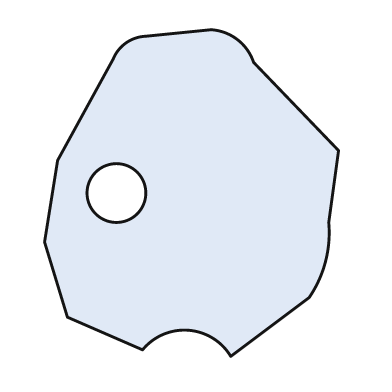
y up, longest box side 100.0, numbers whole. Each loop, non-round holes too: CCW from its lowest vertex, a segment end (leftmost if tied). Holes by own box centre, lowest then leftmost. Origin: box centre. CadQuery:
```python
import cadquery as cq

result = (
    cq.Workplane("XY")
    .moveTo(12.0, -50.0)
    .lineTo(36.0, -32.0)
    .threePointArc((41.0, -21.0), (42.0, -9.0))
    .lineTo(45.0, 13.0)
    .lineTo(19.0, 40.0)
    .threePointArc((14.0, 47.0), (6.0, 50.0))
    .lineTo(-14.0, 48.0)
    .threePointArc((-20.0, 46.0), (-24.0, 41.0))
    .lineTo(-41.0, 10.0)
    .lineTo(-45.0, -15.0)
    .lineTo(-38.0, -38.0)
    .lineTo(-15.0, -48.0)
    .threePointArc((-1.0, -42.0), (12.0, -50.0))
    .close()
    .moveTo(-23.0, 0.0)
    .circle(9.0)
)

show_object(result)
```